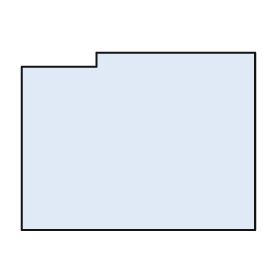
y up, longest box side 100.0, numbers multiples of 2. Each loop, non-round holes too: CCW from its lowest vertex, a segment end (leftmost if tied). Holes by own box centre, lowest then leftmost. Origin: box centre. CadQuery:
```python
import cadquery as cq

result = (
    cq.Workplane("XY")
    .moveTo(-50.0, -38.0)
    .lineTo(50.0, -38.0)
    .lineTo(50.0, 38.0)
    .lineTo(-18.0, 38.0)
    .lineTo(-18.0, 32.0)
    .lineTo(-50.0, 32.0)
    .close()
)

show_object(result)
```